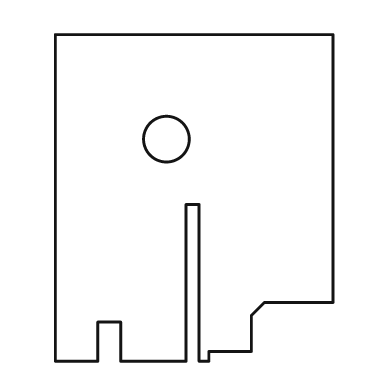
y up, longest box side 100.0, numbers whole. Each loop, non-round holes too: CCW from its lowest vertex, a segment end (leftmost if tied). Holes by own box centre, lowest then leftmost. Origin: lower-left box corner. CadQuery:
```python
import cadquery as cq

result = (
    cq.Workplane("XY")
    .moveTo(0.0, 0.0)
    .lineTo(13.0, 0.0)
    .lineTo(13.0, 12.0)
    .lineTo(20.0, 12.0)
    .lineTo(20.0, 0.0)
    .lineTo(40.0, 0.0)
    .lineTo(40.0, 48.0)
    .lineTo(44.0, 48.0)
    .lineTo(44.0, 0.0)
    .lineTo(47.0, 0.0)
    .lineTo(47.0, 3.0)
    .lineTo(60.0, 3.0)
    .lineTo(60.0, 14.0)
    .lineTo(64.0, 18.0)
    .lineTo(85.0, 18.0)
    .lineTo(85.0, 100.0)
    .lineTo(0.0, 100.0)
    .close()
    .moveTo(34.0, 68.0)
    .circle(7.0)
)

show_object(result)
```